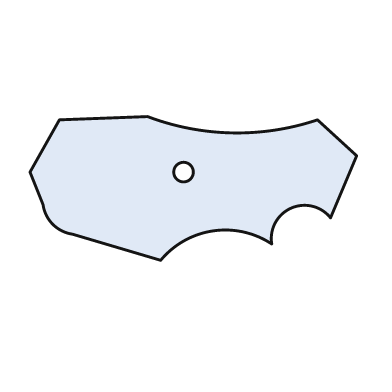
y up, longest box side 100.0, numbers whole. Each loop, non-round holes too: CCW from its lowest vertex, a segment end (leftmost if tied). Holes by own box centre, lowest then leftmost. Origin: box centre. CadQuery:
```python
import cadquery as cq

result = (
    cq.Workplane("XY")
    .moveTo(-10.0, -22.0)
    .threePointArc((6.0, -13.0), (24.0, -17.0))
    .threePointArc((30.0, -6.0), (42.0, -9.0))
    .lineTo(50.0, 10.0)
    .lineTo(38.0, 21.0)
    .threePointArc((12.0, 17.0), (-14.0, 22.0))
    .lineTo(-41.0, 21.0)
    .lineTo(-50.0, 5.0)
    .lineTo(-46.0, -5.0)
    .threePointArc((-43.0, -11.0), (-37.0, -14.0))
    .close()
    .moveTo(-3.0, 5.0)
    .circle(3.0)
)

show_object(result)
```